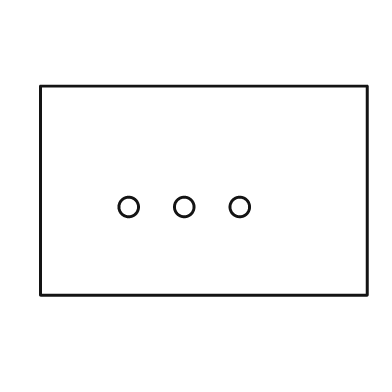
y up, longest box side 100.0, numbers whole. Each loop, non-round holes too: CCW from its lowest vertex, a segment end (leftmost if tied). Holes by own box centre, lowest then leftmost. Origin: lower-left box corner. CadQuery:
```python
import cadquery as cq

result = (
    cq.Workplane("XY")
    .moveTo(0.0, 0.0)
    .lineTo(100.0, 0.0)
    .lineTo(100.0, 64.0)
    .lineTo(0.0, 64.0)
    .close()
    .moveTo(27.0, 27.0)
    .circle(3.0)
    .moveTo(44.0, 27.0)
    .circle(3.0)
    .moveTo(61.0, 27.0)
    .circle(3.0)
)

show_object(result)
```